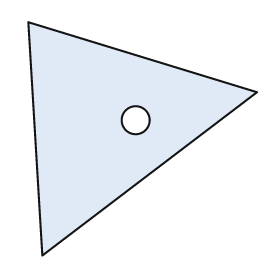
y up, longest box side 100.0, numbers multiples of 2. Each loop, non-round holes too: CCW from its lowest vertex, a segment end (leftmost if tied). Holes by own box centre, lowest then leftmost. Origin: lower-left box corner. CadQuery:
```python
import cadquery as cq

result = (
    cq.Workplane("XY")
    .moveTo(6.0, 0.0)
    .lineTo(98.0, 70.0)
    .lineTo(0.0, 100.0)
    .close()
    .moveTo(46.0, 58.0)
    .circle(6.0)
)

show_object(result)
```